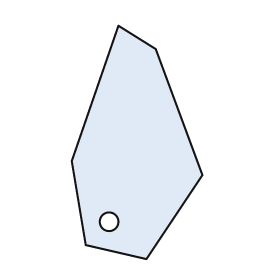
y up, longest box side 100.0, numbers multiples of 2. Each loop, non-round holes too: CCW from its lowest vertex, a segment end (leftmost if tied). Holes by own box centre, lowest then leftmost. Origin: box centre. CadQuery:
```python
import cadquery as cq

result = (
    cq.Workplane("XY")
    .moveTo(4.0, -50.0)
    .lineTo(28.0, -14.0)
    .lineTo(8.0, 40.0)
    .lineTo(-8.0, 50.0)
    .lineTo(-28.0, -8.0)
    .lineTo(-22.0, -44.0)
    .close()
    .moveTo(-12.0, -34.0)
    .circle(4.0)
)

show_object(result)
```